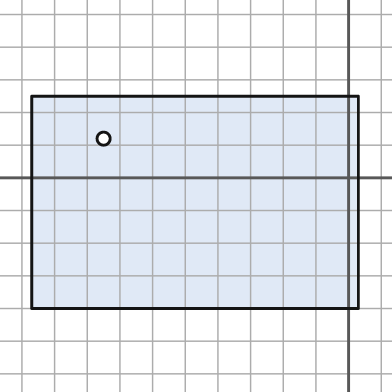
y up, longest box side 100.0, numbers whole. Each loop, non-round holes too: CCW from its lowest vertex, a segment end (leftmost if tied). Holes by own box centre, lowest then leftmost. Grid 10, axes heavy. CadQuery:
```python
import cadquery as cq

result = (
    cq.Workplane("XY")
    .moveTo(-97.0, -40.0)
    .lineTo(3.0, -40.0)
    .lineTo(3.0, 25.0)
    .lineTo(-97.0, 25.0)
    .close()
    .moveTo(-75.0, 12.0)
    .circle(2.0)
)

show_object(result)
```